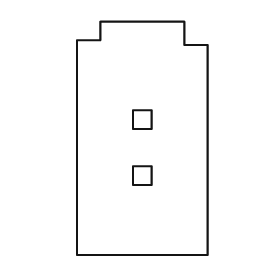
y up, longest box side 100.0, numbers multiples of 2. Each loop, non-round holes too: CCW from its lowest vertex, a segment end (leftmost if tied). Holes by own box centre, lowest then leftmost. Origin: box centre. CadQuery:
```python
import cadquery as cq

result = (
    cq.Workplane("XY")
    .moveTo(-28.0, -50.0)
    .lineTo(28.0, -50.0)
    .lineTo(28.0, 40.0)
    .lineTo(18.0, 40.0)
    .lineTo(18.0, 50.0)
    .lineTo(-18.0, 50.0)
    .lineTo(-18.0, 42.0)
    .lineTo(-28.0, 42.0)
    .close()
    .moveTo(-4.0, -20.0)
    .lineTo(4.0, -20.0)
    .lineTo(4.0, -12.0)
    .lineTo(-4.0, -12.0)
    .close()
    .moveTo(-4.0, 4.0)
    .lineTo(4.0, 4.0)
    .lineTo(4.0, 12.0)
    .lineTo(-4.0, 12.0)
    .close()
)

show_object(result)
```